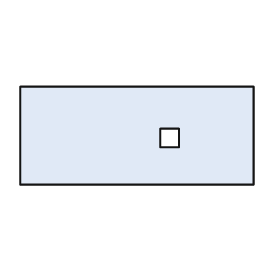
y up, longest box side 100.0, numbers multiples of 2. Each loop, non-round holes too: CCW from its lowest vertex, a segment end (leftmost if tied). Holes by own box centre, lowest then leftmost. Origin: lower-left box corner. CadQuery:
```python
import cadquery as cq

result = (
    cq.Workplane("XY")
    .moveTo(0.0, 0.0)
    .lineTo(100.0, 0.0)
    .lineTo(100.0, 42.0)
    .lineTo(0.0, 42.0)
    .close()
    .moveTo(60.0, 16.0)
    .lineTo(68.0, 16.0)
    .lineTo(68.0, 24.0)
    .lineTo(60.0, 24.0)
    .close()
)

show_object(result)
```